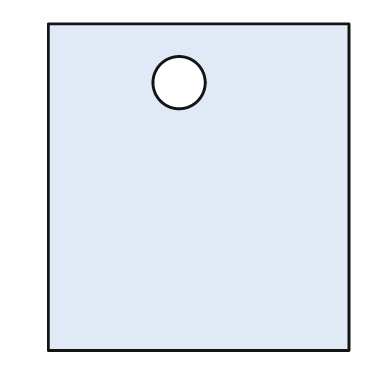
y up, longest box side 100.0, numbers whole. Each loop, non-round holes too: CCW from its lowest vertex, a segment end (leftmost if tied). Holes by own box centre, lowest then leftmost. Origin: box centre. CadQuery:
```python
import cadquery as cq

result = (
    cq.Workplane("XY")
    .moveTo(-46.0, -50.0)
    .lineTo(46.0, -50.0)
    .lineTo(46.0, 50.0)
    .lineTo(-46.0, 50.0)
    .close()
    .moveTo(-6.0, 32.0)
    .circle(8.0)
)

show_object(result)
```